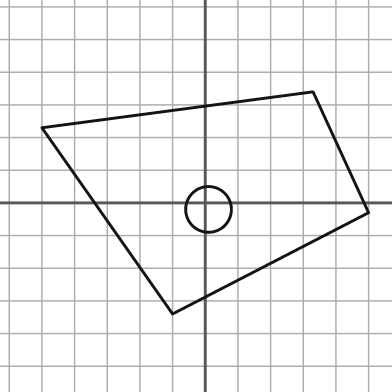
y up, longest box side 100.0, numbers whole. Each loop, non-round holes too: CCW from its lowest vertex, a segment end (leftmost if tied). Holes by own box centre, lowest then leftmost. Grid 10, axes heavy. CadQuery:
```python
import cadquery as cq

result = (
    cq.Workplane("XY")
    .moveTo(-10.0, -34.0)
    .lineTo(50.0, -3.0)
    .lineTo(33.0, 34.0)
    .lineTo(-50.0, 23.0)
    .close()
    .moveTo(1.0, -2.0)
    .circle(7.0)
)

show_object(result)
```